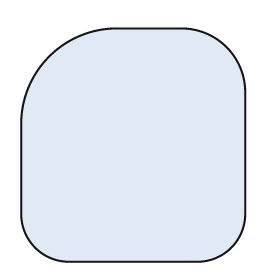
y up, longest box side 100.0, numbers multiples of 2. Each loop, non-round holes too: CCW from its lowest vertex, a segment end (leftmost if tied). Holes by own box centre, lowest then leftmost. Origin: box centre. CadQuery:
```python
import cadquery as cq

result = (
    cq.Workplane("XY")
    .moveTo(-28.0, -50.0)
    .lineTo(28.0, -50.0)
    .threePointArc((42.0, -44.0), (48.0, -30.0))
    .lineTo(48.0, 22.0)
    .threePointArc((40.0, 42.0), (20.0, 50.0))
    .lineTo(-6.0, 50.0)
    .threePointArc((-36.0, 38.0), (-48.0, 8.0))
    .lineTo(-48.0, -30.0)
    .threePointArc((-42.0, -44.0), (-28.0, -50.0))
    .close()
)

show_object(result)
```